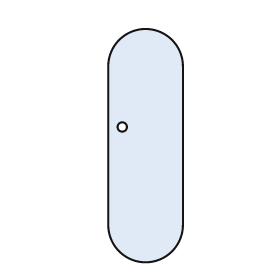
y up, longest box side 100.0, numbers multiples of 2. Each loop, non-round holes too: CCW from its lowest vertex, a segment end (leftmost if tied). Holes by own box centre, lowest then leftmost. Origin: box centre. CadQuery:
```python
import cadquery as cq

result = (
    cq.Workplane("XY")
    .moveTo(-16.0, -34.0)
    .threePointArc((0.0, -50.0), (16.0, -34.0))
    .lineTo(16.0, 34.0)
    .threePointArc((0.0, 50.0), (-16.0, 34.0))
    .close()
    .moveTo(-10.0, 8.0)
    .circle(2.0)
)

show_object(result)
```